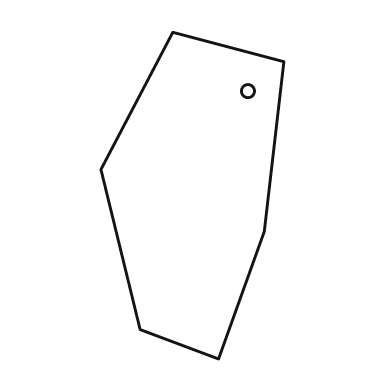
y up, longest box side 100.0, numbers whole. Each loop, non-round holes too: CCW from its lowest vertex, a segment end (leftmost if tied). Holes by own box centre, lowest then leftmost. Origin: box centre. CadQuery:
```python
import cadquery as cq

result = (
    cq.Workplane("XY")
    .moveTo(8.0, -50.0)
    .lineTo(22.0, -11.0)
    .lineTo(28.0, 41.0)
    .lineTo(-6.0, 50.0)
    .lineTo(-28.0, 8.0)
    .lineTo(-16.0, -41.0)
    .close()
    .moveTo(17.0, 32.0)
    .circle(2.0)
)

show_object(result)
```